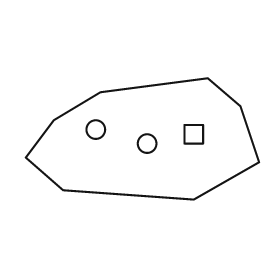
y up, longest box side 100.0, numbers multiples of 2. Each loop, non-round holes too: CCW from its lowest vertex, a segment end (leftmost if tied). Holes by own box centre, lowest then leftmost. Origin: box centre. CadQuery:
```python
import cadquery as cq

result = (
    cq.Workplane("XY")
    .moveTo(22.0, -26.0)
    .lineTo(50.0, -10.0)
    .lineTo(42.0, 14.0)
    .lineTo(28.0, 26.0)
    .lineTo(-18.0, 20.0)
    .lineTo(-38.0, 8.0)
    .lineTo(-50.0, -8.0)
    .lineTo(-34.0, -22.0)
    .close()
    .moveTo(2.0, -2.0)
    .circle(4.0)
    .moveTo(18.0, -2.0)
    .lineTo(26.0, -2.0)
    .lineTo(26.0, 6.0)
    .lineTo(18.0, 6.0)
    .close()
    .moveTo(-20.0, 4.0)
    .circle(4.0)
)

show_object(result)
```